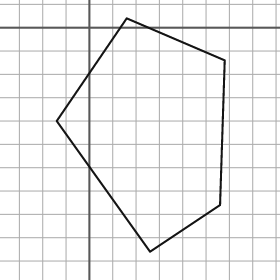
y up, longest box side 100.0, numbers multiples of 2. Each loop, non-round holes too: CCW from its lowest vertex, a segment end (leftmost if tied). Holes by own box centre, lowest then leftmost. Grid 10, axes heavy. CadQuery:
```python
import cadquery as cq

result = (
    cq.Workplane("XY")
    .moveTo(26.0, -96.0)
    .lineTo(56.0, -76.0)
    .lineTo(58.0, -14.0)
    .lineTo(16.0, 4.0)
    .lineTo(-14.0, -40.0)
    .close()
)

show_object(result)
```